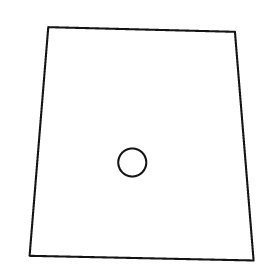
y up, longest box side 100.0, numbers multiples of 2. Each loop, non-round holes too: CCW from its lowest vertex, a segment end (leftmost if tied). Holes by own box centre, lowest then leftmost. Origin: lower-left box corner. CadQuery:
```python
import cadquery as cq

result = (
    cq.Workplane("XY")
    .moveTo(96.0, 0.0)
    .lineTo(88.0, 98.0)
    .lineTo(8.0, 100.0)
    .lineTo(0.0, 2.0)
    .close()
    .moveTo(44.0, 42.0)
    .circle(6.0)
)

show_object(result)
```